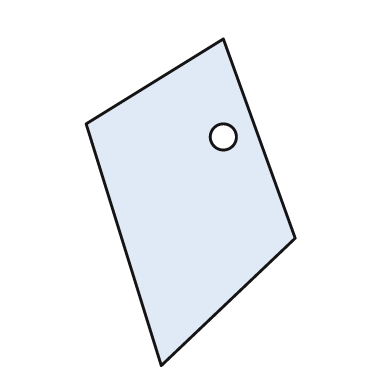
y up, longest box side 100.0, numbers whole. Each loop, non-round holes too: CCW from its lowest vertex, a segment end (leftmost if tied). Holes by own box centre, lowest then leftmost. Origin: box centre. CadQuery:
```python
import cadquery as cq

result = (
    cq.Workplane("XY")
    .moveTo(-9.0, -50.0)
    .lineTo(32.0, -11.0)
    .lineTo(10.0, 50.0)
    .lineTo(-32.0, 24.0)
    .close()
    .moveTo(10.0, 20.0)
    .circle(4.0)
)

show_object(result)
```